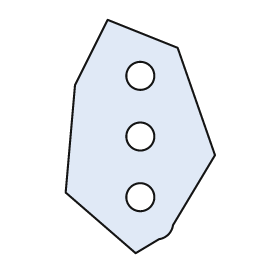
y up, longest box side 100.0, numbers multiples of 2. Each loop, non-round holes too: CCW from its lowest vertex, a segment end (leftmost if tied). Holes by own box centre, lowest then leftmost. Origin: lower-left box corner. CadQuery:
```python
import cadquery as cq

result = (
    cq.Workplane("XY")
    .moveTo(30.0, 0.0)
    .lineTo(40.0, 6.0)
    .threePointArc((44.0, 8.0), (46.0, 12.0))
    .lineTo(64.0, 42.0)
    .lineTo(48.0, 88.0)
    .lineTo(18.0, 100.0)
    .lineTo(4.0, 72.0)
    .lineTo(0.0, 26.0)
    .close()
    .moveTo(32.0, 24.0)
    .circle(6.0)
    .moveTo(32.0, 50.0)
    .circle(6.0)
    .moveTo(32.0, 76.0)
    .circle(6.0)
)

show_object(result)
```